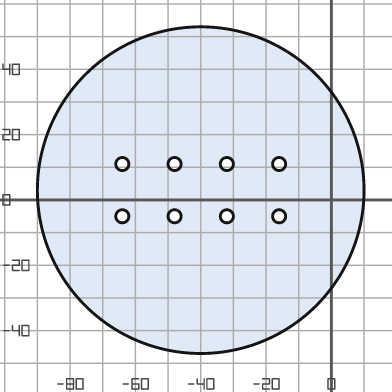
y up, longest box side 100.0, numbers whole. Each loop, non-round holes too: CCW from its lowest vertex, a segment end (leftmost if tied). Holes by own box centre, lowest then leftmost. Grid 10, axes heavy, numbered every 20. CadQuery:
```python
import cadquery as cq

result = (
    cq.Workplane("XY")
    .moveTo(-40.0, 3.0)
    .circle(50.0)
    .moveTo(-64.0, -5.0)
    .circle(2.0)
    .moveTo(-48.0, -5.0)
    .circle(2.0)
    .moveTo(-32.0, -5.0)
    .circle(2.0)
    .moveTo(-16.0, -5.0)
    .circle(2.0)
    .moveTo(-64.0, 11.0)
    .circle(2.0)
    .moveTo(-48.0, 11.0)
    .circle(2.0)
    .moveTo(-32.0, 11.0)
    .circle(2.0)
    .moveTo(-16.0, 11.0)
    .circle(2.0)
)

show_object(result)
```